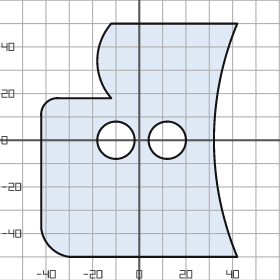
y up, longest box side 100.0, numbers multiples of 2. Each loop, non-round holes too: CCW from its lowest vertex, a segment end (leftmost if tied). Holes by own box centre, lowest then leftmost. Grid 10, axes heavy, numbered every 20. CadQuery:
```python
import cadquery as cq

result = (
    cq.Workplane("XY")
    .moveTo(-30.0, -50.0)
    .lineTo(42.0, -50.0)
    .threePointArc((32.0, 0.0), (42.0, 50.0))
    .lineTo(-12.0, 50.0)
    .threePointArc((-18.0, 34.0), (-12.0, 18.0))
    .lineTo(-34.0, 18.0)
    .threePointArc((-40.0, 16.0), (-42.0, 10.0))
    .lineTo(-42.0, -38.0)
    .threePointArc((-38.0, -46.0), (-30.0, -50.0))
    .close()
    .moveTo(-10.0, 0.0)
    .circle(8.0)
    .moveTo(12.0, 0.0)
    .circle(8.0)
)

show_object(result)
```